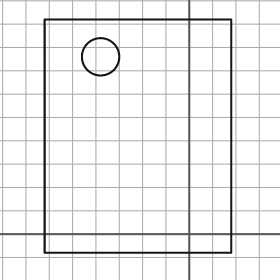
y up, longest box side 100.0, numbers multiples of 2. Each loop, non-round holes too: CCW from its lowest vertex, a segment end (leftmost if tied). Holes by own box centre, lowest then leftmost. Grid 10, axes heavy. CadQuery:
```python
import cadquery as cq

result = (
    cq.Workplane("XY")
    .moveTo(-62.0, -8.0)
    .lineTo(18.0, -8.0)
    .lineTo(18.0, 92.0)
    .lineTo(-62.0, 92.0)
    .close()
    .moveTo(-38.0, 76.0)
    .circle(8.0)
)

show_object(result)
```